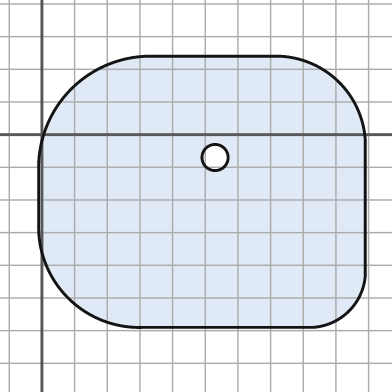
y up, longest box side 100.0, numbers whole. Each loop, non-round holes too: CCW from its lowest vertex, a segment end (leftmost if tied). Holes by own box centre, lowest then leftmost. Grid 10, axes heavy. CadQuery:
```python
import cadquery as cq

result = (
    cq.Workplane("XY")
    .moveTo(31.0, -59.0)
    .lineTo(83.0, -59.0)
    .threePointArc((94.0, -54.0), (99.0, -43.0))
    .lineTo(99.0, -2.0)
    .threePointArc((91.0, 16.0), (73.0, 24.0))
    .lineTo(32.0, 24.0)
    .threePointArc((9.0, 14.0), (-1.0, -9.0))
    .lineTo(-1.0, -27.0)
    .threePointArc((8.0, -50.0), (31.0, -59.0))
    .close()
    .moveTo(53.0, -7.0)
    .circle(4.0)
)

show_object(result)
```